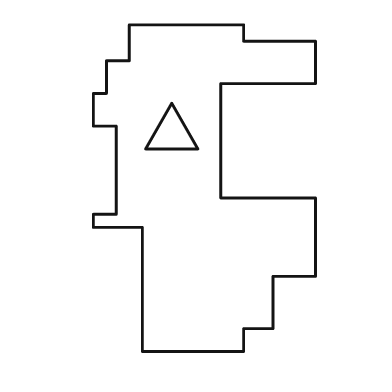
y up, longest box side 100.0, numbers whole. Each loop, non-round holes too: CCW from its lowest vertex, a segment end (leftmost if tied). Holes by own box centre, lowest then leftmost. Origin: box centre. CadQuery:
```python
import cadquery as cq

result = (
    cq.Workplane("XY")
    .moveTo(-19.0, -50.0)
    .lineTo(12.0, -50.0)
    .lineTo(12.0, -43.0)
    .lineTo(21.0, -43.0)
    .lineTo(21.0, -27.0)
    .lineTo(34.0, -27.0)
    .lineTo(34.0, -3.0)
    .lineTo(5.0, -3.0)
    .lineTo(5.0, 32.0)
    .lineTo(34.0, 32.0)
    .lineTo(34.0, 45.0)
    .lineTo(12.0, 45.0)
    .lineTo(12.0, 50.0)
    .lineTo(-23.0, 50.0)
    .lineTo(-23.0, 39.0)
    .lineTo(-30.0, 39.0)
    .lineTo(-30.0, 29.0)
    .lineTo(-34.0, 29.0)
    .lineTo(-34.0, 19.0)
    .lineTo(-27.0, 19.0)
    .lineTo(-27.0, -8.0)
    .lineTo(-34.0, -8.0)
    .lineTo(-34.0, -12.0)
    .lineTo(-19.0, -12.0)
    .close()
    .moveTo(-18.0, 12.0)
    .lineTo(-2.0, 12.0)
    .lineTo(-10.0, 26.0)
    .close()
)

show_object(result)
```